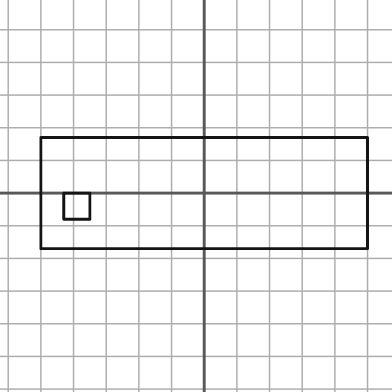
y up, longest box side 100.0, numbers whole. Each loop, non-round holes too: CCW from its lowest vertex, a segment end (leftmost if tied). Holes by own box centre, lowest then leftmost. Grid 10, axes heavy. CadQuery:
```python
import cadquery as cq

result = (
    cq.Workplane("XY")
    .moveTo(-50.0, -17.0)
    .lineTo(50.0, -17.0)
    .lineTo(50.0, 17.0)
    .lineTo(-50.0, 17.0)
    .close()
    .moveTo(-43.0, -8.0)
    .lineTo(-35.0, -8.0)
    .lineTo(-35.0, 0.0)
    .lineTo(-43.0, 0.0)
    .close()
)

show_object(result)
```